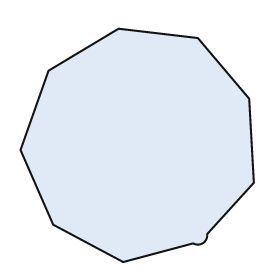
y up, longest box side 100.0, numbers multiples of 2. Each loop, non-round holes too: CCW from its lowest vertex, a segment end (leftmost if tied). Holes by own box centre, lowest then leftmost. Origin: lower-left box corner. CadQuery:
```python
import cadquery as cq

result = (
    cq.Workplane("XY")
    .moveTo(44.0, 0.0)
    .lineTo(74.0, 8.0)
    .threePointArc((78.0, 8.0), (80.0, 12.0))
    .lineTo(100.0, 34.0)
    .lineTo(98.0, 70.0)
    .lineTo(76.0, 96.0)
    .lineTo(42.0, 100.0)
    .lineTo(12.0, 82.0)
    .lineTo(0.0, 48.0)
    .lineTo(14.0, 16.0)
    .close()
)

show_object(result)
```